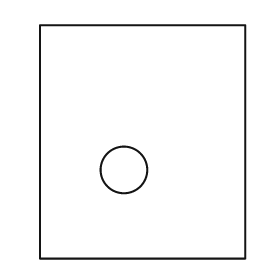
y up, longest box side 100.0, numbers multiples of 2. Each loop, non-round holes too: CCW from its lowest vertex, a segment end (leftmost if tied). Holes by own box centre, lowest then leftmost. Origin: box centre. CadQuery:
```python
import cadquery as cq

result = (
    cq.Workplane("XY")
    .moveTo(-44.0, -50.0)
    .lineTo(44.0, -50.0)
    .lineTo(44.0, 50.0)
    .lineTo(-44.0, 50.0)
    .close()
    .moveTo(-8.0, -12.0)
    .circle(10.0)
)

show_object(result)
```